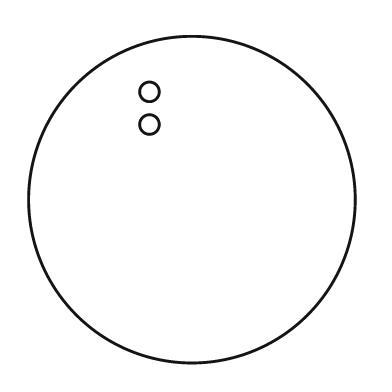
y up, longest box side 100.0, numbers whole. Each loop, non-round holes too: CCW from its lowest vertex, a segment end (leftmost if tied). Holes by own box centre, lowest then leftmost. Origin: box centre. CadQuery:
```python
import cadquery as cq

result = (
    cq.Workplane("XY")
    .moveTo(0.0, 0.0)
    .circle(50.0)
    .moveTo(-13.0, 23.0)
    .circle(3.0)
    .moveTo(-13.0, 33.0)
    .circle(3.0)
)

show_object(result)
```